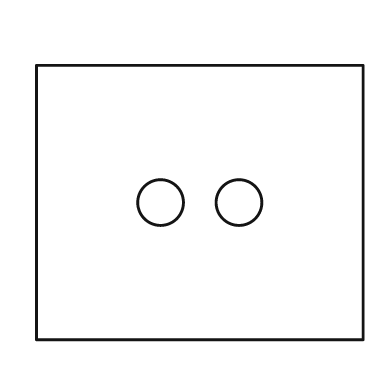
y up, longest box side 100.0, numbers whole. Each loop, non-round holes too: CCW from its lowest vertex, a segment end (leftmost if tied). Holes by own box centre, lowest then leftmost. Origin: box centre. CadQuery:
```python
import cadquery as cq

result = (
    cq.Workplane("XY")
    .moveTo(-50.0, -42.0)
    .lineTo(50.0, -42.0)
    .lineTo(50.0, 42.0)
    .lineTo(-50.0, 42.0)
    .close()
    .moveTo(-12.0, 0.0)
    .circle(7.0)
    .moveTo(12.0, 0.0)
    .circle(7.0)
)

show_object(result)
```